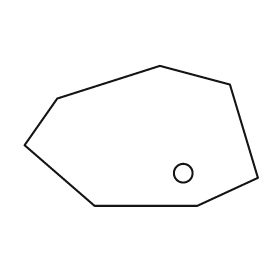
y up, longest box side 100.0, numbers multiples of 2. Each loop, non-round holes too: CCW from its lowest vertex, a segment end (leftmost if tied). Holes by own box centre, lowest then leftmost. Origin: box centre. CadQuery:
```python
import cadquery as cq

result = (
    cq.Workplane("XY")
    .moveTo(-20.0, -30.0)
    .lineTo(24.0, -30.0)
    .lineTo(50.0, -18.0)
    .lineTo(38.0, 22.0)
    .lineTo(8.0, 30.0)
    .lineTo(-36.0, 16.0)
    .lineTo(-50.0, -4.0)
    .close()
    .moveTo(18.0, -16.0)
    .circle(4.0)
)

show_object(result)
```